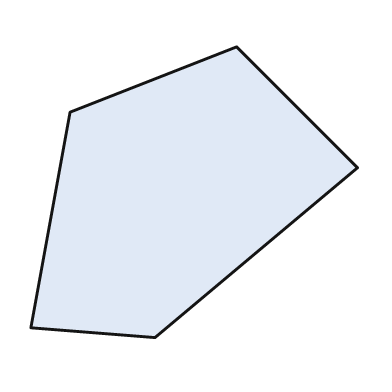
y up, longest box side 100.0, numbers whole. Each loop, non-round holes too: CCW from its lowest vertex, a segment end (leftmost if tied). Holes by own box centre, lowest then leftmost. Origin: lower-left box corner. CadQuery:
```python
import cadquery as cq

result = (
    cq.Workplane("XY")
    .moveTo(38.0, 0.0)
    .lineTo(100.0, 52.0)
    .lineTo(63.0, 89.0)
    .lineTo(12.0, 69.0)
    .lineTo(0.0, 3.0)
    .close()
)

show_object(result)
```